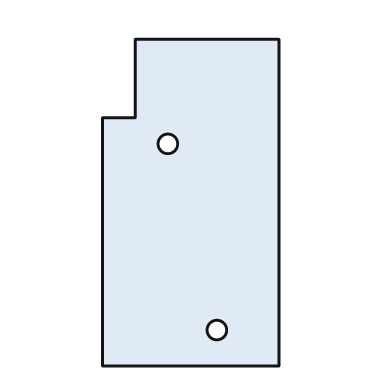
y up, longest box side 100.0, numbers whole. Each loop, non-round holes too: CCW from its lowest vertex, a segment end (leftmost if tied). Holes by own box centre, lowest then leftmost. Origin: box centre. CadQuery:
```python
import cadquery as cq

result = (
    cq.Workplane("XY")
    .moveTo(-27.0, -50.0)
    .lineTo(27.0, -50.0)
    .lineTo(27.0, 50.0)
    .lineTo(-17.0, 50.0)
    .lineTo(-17.0, 26.0)
    .lineTo(-27.0, 26.0)
    .close()
    .moveTo(8.0, -39.0)
    .circle(3.0)
    .moveTo(-7.0, 18.0)
    .circle(3.0)
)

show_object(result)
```